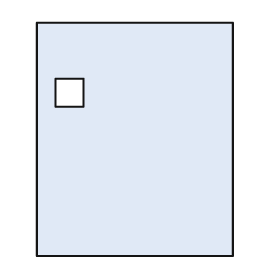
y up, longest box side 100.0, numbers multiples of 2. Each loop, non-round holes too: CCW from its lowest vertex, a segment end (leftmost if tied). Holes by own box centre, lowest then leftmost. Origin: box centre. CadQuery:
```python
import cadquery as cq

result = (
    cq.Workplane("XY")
    .moveTo(-42.0, -50.0)
    .lineTo(42.0, -50.0)
    .lineTo(42.0, 50.0)
    .lineTo(-42.0, 50.0)
    .close()
    .moveTo(-34.0, 14.0)
    .lineTo(-22.0, 14.0)
    .lineTo(-22.0, 26.0)
    .lineTo(-34.0, 26.0)
    .close()
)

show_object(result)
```